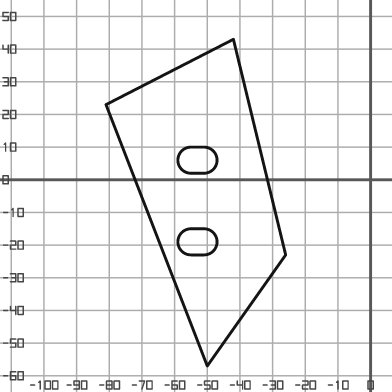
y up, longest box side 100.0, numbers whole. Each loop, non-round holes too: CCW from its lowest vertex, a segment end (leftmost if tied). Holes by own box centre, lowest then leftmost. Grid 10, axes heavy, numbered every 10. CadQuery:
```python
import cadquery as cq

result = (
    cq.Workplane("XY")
    .moveTo(-50.0, -57.0)
    .lineTo(-26.0, -23.0)
    .lineTo(-42.0, 43.0)
    .lineTo(-81.0, 23.0)
    .close()
    .moveTo(-55.0, -23.0)
    .lineTo(-51.0, -23.0)
    .threePointArc((-47.0, -19.0), (-51.0, -15.0))
    .lineTo(-55.0, -15.0)
    .threePointArc((-59.0, -19.0), (-55.0, -23.0))
    .close()
    .moveTo(-55.0, 2.0)
    .lineTo(-51.0, 2.0)
    .threePointArc((-47.0, 6.0), (-51.0, 10.0))
    .lineTo(-55.0, 10.0)
    .threePointArc((-59.0, 6.0), (-55.0, 2.0))
    .close()
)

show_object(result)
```